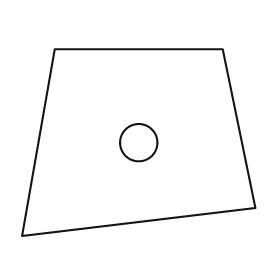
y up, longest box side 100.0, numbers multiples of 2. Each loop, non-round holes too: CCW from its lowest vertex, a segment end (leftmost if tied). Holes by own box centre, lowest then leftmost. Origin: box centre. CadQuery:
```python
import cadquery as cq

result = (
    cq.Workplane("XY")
    .moveTo(-50.0, -40.0)
    .lineTo(50.0, -28.0)
    .lineTo(36.0, 40.0)
    .lineTo(-36.0, 40.0)
    .close()
    .moveTo(0.0, 0.0)
    .circle(8.0)
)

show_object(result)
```